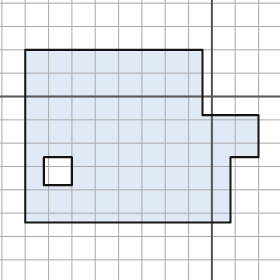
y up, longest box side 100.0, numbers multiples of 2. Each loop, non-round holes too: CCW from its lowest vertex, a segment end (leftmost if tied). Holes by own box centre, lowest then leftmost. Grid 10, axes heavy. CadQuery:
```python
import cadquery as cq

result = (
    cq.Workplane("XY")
    .moveTo(-80.0, -54.0)
    .lineTo(8.0, -54.0)
    .lineTo(8.0, -26.0)
    .lineTo(20.0, -26.0)
    .lineTo(20.0, -8.0)
    .lineTo(-4.0, -8.0)
    .lineTo(-4.0, 20.0)
    .lineTo(-80.0, 20.0)
    .close()
    .moveTo(-72.0, -38.0)
    .lineTo(-60.0, -38.0)
    .lineTo(-60.0, -26.0)
    .lineTo(-72.0, -26.0)
    .close()
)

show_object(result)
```